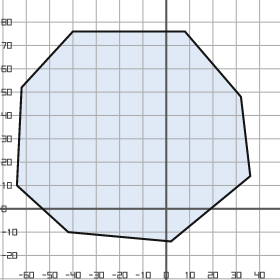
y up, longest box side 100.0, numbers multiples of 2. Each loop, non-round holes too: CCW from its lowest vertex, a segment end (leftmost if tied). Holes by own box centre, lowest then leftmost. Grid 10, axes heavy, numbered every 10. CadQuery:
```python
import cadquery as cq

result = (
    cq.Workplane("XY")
    .moveTo(2.0, -14.0)
    .lineTo(36.0, 14.0)
    .lineTo(32.0, 48.0)
    .lineTo(8.0, 76.0)
    .lineTo(-40.0, 76.0)
    .lineTo(-62.0, 52.0)
    .lineTo(-64.0, 10.0)
    .lineTo(-42.0, -10.0)
    .close()
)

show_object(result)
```